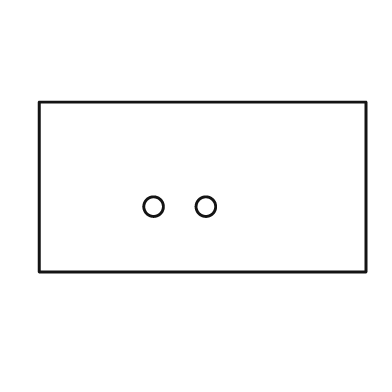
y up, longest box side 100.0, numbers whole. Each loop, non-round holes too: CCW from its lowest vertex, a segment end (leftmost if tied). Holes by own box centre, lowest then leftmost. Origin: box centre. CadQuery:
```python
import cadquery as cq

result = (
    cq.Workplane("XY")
    .moveTo(-50.0, -26.0)
    .lineTo(50.0, -26.0)
    .lineTo(50.0, 26.0)
    .lineTo(-50.0, 26.0)
    .close()
    .moveTo(-15.0, -6.0)
    .circle(3.0)
    .moveTo(1.0, -6.0)
    .circle(3.0)
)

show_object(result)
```